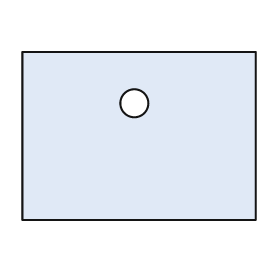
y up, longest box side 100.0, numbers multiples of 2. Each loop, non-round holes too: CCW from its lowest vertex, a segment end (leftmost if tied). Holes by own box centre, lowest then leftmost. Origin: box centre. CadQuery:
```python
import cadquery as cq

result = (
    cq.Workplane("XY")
    .moveTo(-50.0, -36.0)
    .lineTo(50.0, -36.0)
    .lineTo(50.0, 36.0)
    .lineTo(-50.0, 36.0)
    .close()
    .moveTo(-2.0, 14.0)
    .circle(6.0)
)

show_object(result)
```